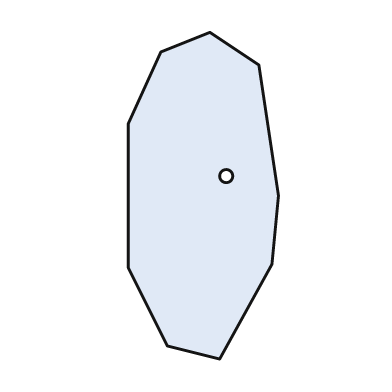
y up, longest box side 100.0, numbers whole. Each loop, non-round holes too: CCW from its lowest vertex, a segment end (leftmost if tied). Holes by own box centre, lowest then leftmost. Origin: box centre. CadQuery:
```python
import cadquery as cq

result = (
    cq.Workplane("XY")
    .moveTo(5.0, -50.0)
    .lineTo(21.0, -21.0)
    .lineTo(23.0, 0.0)
    .lineTo(17.0, 40.0)
    .lineTo(2.0, 50.0)
    .lineTo(-13.0, 44.0)
    .lineTo(-23.0, 22.0)
    .lineTo(-23.0, -22.0)
    .lineTo(-11.0, -46.0)
    .close()
    .moveTo(7.0, 6.0)
    .circle(2.0)
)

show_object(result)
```